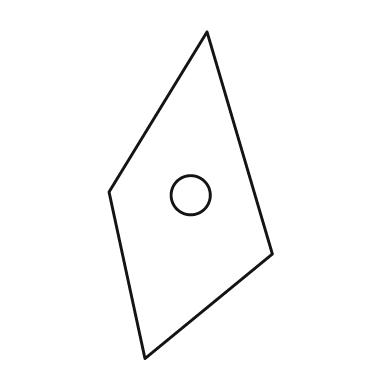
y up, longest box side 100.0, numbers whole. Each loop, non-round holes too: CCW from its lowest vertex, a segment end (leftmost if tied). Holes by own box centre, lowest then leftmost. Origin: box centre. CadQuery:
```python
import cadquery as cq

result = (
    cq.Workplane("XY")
    .moveTo(-14.0, -50.0)
    .lineTo(25.0, -18.0)
    .lineTo(5.0, 50.0)
    .lineTo(-25.0, 1.0)
    .close()
    .moveTo(0.0, 0.0)
    .circle(6.0)
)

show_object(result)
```